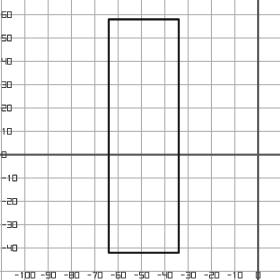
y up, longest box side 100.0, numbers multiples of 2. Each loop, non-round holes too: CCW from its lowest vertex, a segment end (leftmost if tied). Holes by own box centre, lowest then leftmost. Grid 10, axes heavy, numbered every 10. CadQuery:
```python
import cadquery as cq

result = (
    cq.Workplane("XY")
    .moveTo(-64.0, -42.0)
    .lineTo(-34.0, -42.0)
    .lineTo(-34.0, 58.0)
    .lineTo(-64.0, 58.0)
    .close()
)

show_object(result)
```